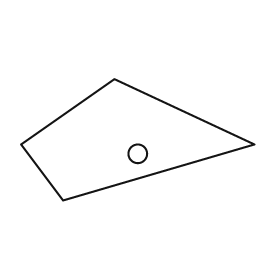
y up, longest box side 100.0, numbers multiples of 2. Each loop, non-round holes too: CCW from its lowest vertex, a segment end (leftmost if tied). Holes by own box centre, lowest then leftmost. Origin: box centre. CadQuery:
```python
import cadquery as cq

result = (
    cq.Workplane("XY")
    .moveTo(-32.0, -26.0)
    .lineTo(50.0, -2.0)
    .lineTo(-10.0, 26.0)
    .lineTo(-50.0, -2.0)
    .close()
    .moveTo(0.0, -6.0)
    .circle(4.0)
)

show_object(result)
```